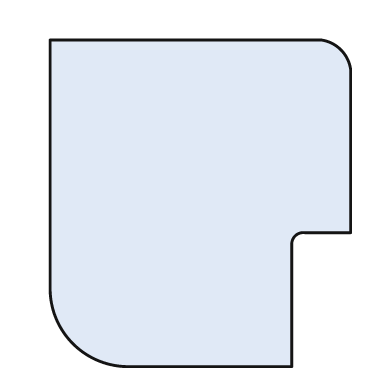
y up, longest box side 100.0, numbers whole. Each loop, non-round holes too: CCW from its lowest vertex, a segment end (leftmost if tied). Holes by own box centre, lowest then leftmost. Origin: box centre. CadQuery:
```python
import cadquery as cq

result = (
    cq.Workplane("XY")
    .moveTo(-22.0, -50.0)
    .lineTo(28.0, -50.0)
    .lineTo(28.0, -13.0)
    .threePointArc((29.0, -10.0), (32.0, -9.0))
    .lineTo(46.0, -9.0)
    .lineTo(46.0, 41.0)
    .threePointArc((43.0, 47.0), (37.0, 50.0))
    .lineTo(-46.0, 50.0)
    .lineTo(-46.0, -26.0)
    .threePointArc((-39.0, -43.0), (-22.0, -50.0))
    .close()
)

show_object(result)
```